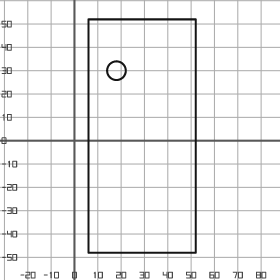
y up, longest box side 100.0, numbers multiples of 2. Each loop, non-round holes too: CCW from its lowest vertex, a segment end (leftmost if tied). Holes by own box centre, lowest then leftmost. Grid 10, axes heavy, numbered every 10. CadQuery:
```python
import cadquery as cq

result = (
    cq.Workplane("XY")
    .moveTo(6.0, -48.0)
    .lineTo(52.0, -48.0)
    .lineTo(52.0, 52.0)
    .lineTo(6.0, 52.0)
    .close()
    .moveTo(18.0, 30.0)
    .circle(4.0)
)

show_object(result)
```